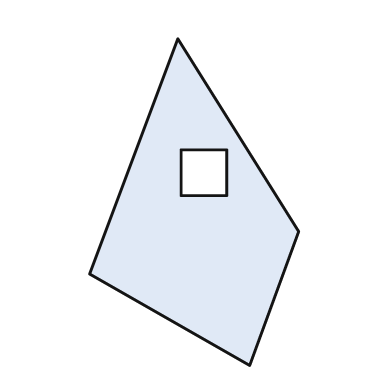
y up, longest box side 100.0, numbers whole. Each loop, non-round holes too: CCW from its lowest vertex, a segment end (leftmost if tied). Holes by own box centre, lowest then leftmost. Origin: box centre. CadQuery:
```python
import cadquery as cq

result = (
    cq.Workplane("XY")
    .moveTo(17.0, -50.0)
    .lineTo(32.0, -9.0)
    .lineTo(-5.0, 50.0)
    .lineTo(-32.0, -22.0)
    .close()
    .moveTo(-4.0, 2.0)
    .lineTo(10.0, 2.0)
    .lineTo(10.0, 16.0)
    .lineTo(-4.0, 16.0)
    .close()
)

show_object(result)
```